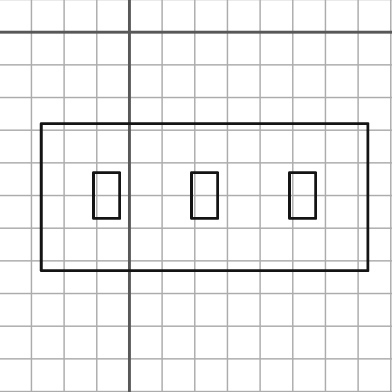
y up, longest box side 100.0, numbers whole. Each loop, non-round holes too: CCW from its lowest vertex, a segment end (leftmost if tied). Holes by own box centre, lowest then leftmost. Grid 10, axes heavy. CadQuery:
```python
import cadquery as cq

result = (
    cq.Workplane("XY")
    .moveTo(-27.0, -73.0)
    .lineTo(73.0, -73.0)
    .lineTo(73.0, -28.0)
    .lineTo(-27.0, -28.0)
    .close()
    .moveTo(-11.0, -57.0)
    .lineTo(-3.0, -57.0)
    .lineTo(-3.0, -43.0)
    .lineTo(-11.0, -43.0)
    .close()
    .moveTo(19.0, -57.0)
    .lineTo(27.0, -57.0)
    .lineTo(27.0, -43.0)
    .lineTo(19.0, -43.0)
    .close()
    .moveTo(49.0, -57.0)
    .lineTo(57.0, -57.0)
    .lineTo(57.0, -43.0)
    .lineTo(49.0, -43.0)
    .close()
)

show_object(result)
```